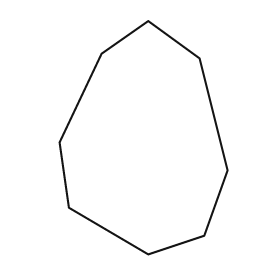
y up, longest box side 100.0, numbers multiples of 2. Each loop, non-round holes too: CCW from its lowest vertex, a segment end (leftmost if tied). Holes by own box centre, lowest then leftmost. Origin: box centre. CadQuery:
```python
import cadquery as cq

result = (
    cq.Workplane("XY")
    .moveTo(2.0, -50.0)
    .lineTo(26.0, -42.0)
    .lineTo(36.0, -14.0)
    .lineTo(24.0, 34.0)
    .lineTo(2.0, 50.0)
    .lineTo(-18.0, 36.0)
    .lineTo(-36.0, -2.0)
    .lineTo(-32.0, -30.0)
    .close()
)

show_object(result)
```